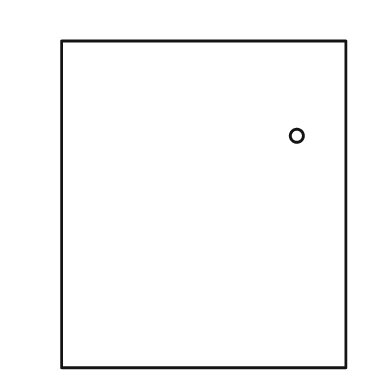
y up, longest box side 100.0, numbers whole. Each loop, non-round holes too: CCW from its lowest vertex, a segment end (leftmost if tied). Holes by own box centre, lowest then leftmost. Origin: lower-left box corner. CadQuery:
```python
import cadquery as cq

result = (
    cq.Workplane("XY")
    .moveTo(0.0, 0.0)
    .lineTo(87.0, 0.0)
    .lineTo(87.0, 100.0)
    .lineTo(0.0, 100.0)
    .close()
    .moveTo(72.0, 71.0)
    .circle(2.0)
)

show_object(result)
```